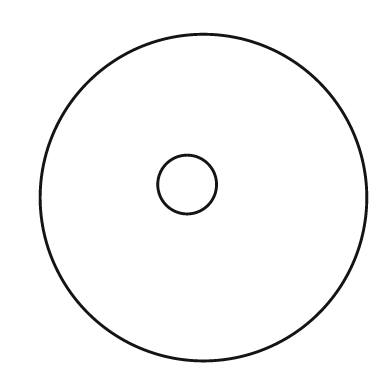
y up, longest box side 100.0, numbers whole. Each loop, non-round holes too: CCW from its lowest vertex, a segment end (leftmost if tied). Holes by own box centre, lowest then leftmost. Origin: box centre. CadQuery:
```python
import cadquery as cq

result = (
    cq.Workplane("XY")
    .moveTo(0.0, 0.0)
    .circle(50.0)
    .moveTo(-5.0, 4.0)
    .circle(9.0)
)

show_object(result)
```